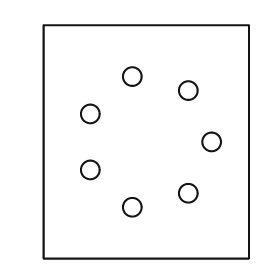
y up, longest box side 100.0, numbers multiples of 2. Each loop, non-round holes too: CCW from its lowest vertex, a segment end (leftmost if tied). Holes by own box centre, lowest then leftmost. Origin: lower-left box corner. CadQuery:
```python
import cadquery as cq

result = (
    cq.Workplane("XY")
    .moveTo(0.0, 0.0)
    .lineTo(88.0, 0.0)
    .lineTo(88.0, 100.0)
    .lineTo(0.0, 100.0)
    .close()
    .moveTo(38.0, 22.0)
    .circle(4.0)
    .moveTo(62.0, 28.0)
    .circle(4.0)
    .moveTo(20.0, 38.0)
    .circle(4.0)
    .moveTo(72.0, 50.0)
    .circle(4.0)
    .moveTo(20.0, 62.0)
    .circle(4.0)
    .moveTo(62.0, 72.0)
    .circle(4.0)
    .moveTo(38.0, 78.0)
    .circle(4.0)
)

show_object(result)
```